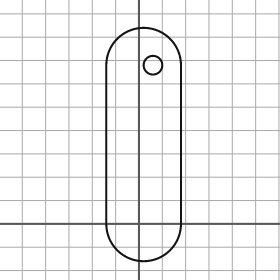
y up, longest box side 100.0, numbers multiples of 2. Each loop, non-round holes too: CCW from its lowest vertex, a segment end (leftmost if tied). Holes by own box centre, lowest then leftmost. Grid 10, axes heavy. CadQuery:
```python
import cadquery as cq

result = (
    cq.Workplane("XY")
    .moveTo(-14.0, 0.0)
    .threePointArc((2.0, -16.0), (18.0, 0.0))
    .lineTo(18.0, 68.0)
    .threePointArc((2.0, 84.0), (-14.0, 68.0))
    .close()
    .moveTo(6.0, 68.0)
    .circle(4.0)
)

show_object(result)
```